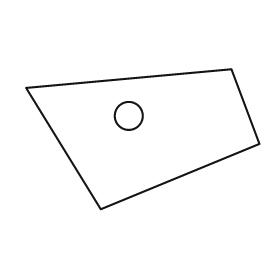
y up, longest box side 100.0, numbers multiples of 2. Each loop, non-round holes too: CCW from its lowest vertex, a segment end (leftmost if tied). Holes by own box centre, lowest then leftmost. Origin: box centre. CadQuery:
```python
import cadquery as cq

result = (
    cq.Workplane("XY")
    .moveTo(-18.0, -30.0)
    .lineTo(50.0, -2.0)
    .lineTo(38.0, 30.0)
    .lineTo(-50.0, 22.0)
    .close()
    .moveTo(-6.0, 10.0)
    .circle(6.0)
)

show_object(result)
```